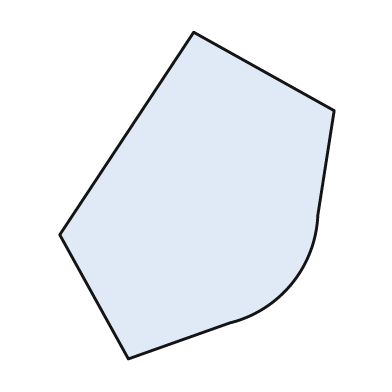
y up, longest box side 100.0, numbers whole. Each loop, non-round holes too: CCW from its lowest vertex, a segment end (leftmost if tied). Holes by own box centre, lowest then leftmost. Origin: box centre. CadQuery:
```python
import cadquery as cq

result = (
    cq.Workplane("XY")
    .moveTo(-21.0, -50.0)
    .lineTo(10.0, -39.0)
    .threePointArc((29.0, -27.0), (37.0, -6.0))
    .lineTo(42.0, 26.0)
    .lineTo(-1.0, 50.0)
    .lineTo(-42.0, -12.0)
    .close()
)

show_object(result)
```